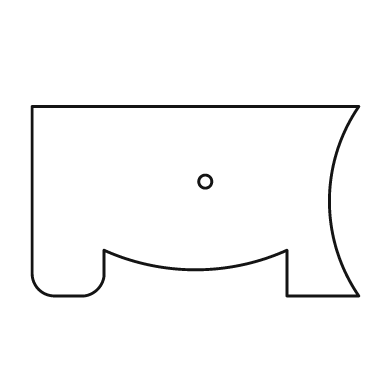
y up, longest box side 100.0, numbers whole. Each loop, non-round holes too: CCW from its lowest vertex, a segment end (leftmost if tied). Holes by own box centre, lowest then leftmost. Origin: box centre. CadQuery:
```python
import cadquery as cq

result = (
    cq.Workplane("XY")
    .moveTo(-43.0, -29.0)
    .lineTo(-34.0, -29.0)
    .threePointArc((-30.0, -27.0), (-28.0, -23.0))
    .lineTo(-28.0, -15.0)
    .threePointArc((0.0, -21.0), (28.0, -15.0))
    .lineTo(28.0, -29.0)
    .lineTo(50.0, -29.0)
    .threePointArc((41.0, 0.0), (50.0, 29.0))
    .lineTo(-50.0, 29.0)
    .lineTo(-50.0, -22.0)
    .threePointArc((-48.0, -27.0), (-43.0, -29.0))
    .close()
    .moveTo(3.0, 6.0)
    .circle(2.0)
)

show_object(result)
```